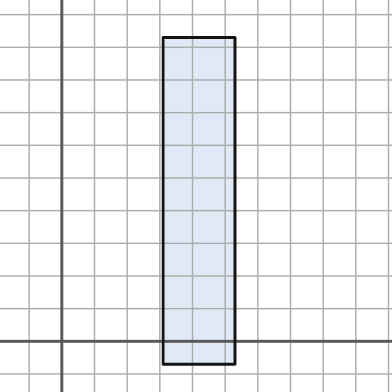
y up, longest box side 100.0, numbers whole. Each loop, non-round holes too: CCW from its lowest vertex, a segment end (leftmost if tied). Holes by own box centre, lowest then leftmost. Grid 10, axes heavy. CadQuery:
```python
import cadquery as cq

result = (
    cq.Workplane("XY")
    .moveTo(31.0, -7.0)
    .lineTo(53.0, -7.0)
    .lineTo(53.0, 93.0)
    .lineTo(31.0, 93.0)
    .close()
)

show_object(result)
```